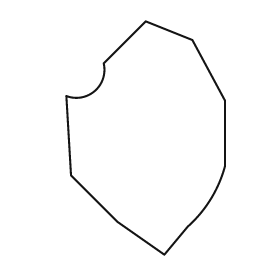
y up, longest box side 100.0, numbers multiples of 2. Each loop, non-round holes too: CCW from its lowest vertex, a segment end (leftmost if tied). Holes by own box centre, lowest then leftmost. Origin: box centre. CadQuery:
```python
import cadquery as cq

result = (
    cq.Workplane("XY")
    .moveTo(8.0, -50.0)
    .lineTo(18.0, -38.0)
    .threePointArc((28.0, -26.0), (34.0, -12.0))
    .lineTo(34.0, 16.0)
    .lineTo(20.0, 42.0)
    .lineTo(0.0, 50.0)
    .lineTo(-18.0, 32.0)
    .threePointArc((-22.0, 20.0), (-34.0, 18.0))
    .lineTo(-32.0, -16.0)
    .lineTo(-12.0, -36.0)
    .close()
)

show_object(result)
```